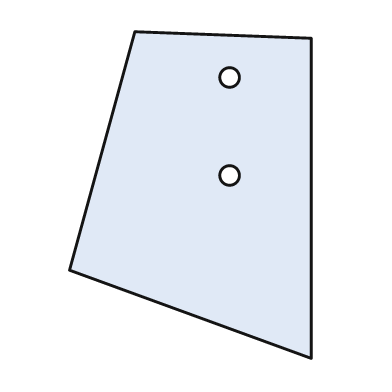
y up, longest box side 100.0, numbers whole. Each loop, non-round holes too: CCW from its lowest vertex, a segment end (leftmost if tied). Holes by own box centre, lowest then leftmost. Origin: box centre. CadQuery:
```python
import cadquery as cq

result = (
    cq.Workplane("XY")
    .moveTo(37.0, -50.0)
    .lineTo(37.0, 48.0)
    .lineTo(-17.0, 50.0)
    .lineTo(-37.0, -23.0)
    .close()
    .moveTo(12.0, 6.0)
    .circle(3.0)
    .moveTo(12.0, 36.0)
    .circle(3.0)
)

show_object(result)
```